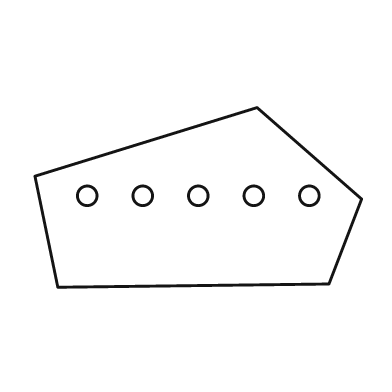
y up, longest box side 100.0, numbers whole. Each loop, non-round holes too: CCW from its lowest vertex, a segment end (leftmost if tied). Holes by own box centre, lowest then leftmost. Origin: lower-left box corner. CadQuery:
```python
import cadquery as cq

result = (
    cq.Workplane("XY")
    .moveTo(7.0, 0.0)
    .lineTo(90.0, 1.0)
    .lineTo(100.0, 27.0)
    .lineTo(68.0, 55.0)
    .lineTo(0.0, 34.0)
    .close()
    .moveTo(16.0, 28.0)
    .circle(3.0)
    .moveTo(33.0, 28.0)
    .circle(3.0)
    .moveTo(50.0, 28.0)
    .circle(3.0)
    .moveTo(67.0, 28.0)
    .circle(3.0)
    .moveTo(84.0, 28.0)
    .circle(3.0)
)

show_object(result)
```